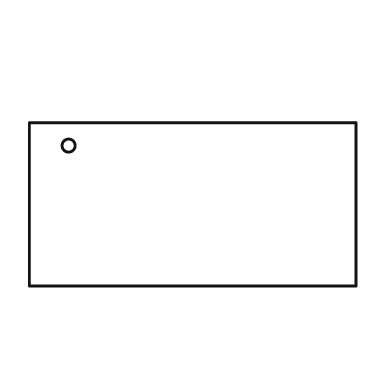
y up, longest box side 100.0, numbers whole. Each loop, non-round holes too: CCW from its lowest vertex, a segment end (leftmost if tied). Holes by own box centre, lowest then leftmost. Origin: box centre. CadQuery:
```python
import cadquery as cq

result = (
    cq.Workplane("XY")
    .moveTo(-50.0, -25.0)
    .lineTo(50.0, -25.0)
    .lineTo(50.0, 25.0)
    .lineTo(-50.0, 25.0)
    .close()
    .moveTo(-38.0, 18.0)
    .circle(2.0)
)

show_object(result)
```